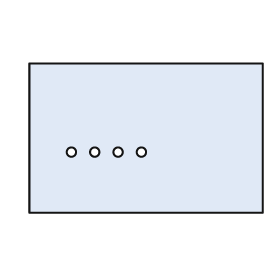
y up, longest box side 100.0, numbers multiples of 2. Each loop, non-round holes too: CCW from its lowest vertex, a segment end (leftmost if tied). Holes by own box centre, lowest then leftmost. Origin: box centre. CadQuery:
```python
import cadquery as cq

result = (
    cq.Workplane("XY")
    .moveTo(-50.0, -32.0)
    .lineTo(50.0, -32.0)
    .lineTo(50.0, 32.0)
    .lineTo(-50.0, 32.0)
    .close()
    .moveTo(-32.0, -6.0)
    .circle(2.0)
    .moveTo(-22.0, -6.0)
    .circle(2.0)
    .moveTo(-12.0, -6.0)
    .circle(2.0)
    .moveTo(-2.0, -6.0)
    .circle(2.0)
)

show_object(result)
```